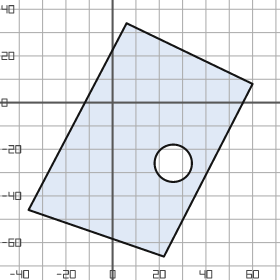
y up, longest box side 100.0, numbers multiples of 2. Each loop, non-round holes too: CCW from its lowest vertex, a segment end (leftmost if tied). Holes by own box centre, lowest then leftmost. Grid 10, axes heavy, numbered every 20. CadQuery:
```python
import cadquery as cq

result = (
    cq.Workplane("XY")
    .moveTo(22.0, -66.0)
    .lineTo(60.0, 8.0)
    .lineTo(6.0, 34.0)
    .lineTo(-36.0, -46.0)
    .close()
    .moveTo(26.0, -26.0)
    .circle(8.0)
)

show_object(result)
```